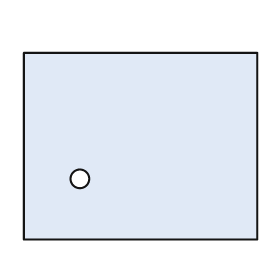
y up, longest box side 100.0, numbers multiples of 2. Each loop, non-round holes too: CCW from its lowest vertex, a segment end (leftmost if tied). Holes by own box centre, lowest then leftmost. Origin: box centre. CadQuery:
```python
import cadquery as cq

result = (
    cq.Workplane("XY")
    .moveTo(-50.0, -40.0)
    .lineTo(50.0, -40.0)
    .lineTo(50.0, 40.0)
    .lineTo(-50.0, 40.0)
    .close()
    .moveTo(-26.0, -14.0)
    .circle(4.0)
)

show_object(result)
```